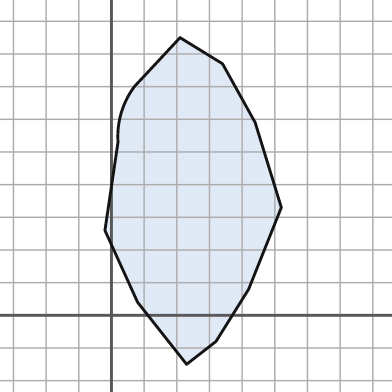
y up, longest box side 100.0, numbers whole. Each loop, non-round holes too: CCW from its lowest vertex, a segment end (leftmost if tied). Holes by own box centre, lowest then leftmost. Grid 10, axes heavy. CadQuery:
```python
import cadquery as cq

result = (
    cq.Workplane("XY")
    .moveTo(23.0, -15.0)
    .lineTo(32.0, -8.0)
    .lineTo(42.0, 8.0)
    .lineTo(52.0, 33.0)
    .lineTo(44.0, 59.0)
    .lineTo(34.0, 77.0)
    .lineTo(21.0, 85.0)
    .lineTo(7.0, 70.0)
    .threePointArc((3.0, 62.0), (2.0, 53.0))
    .lineTo(-2.0, 26.0)
    .lineTo(8.0, 4.0)
    .close()
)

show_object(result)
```